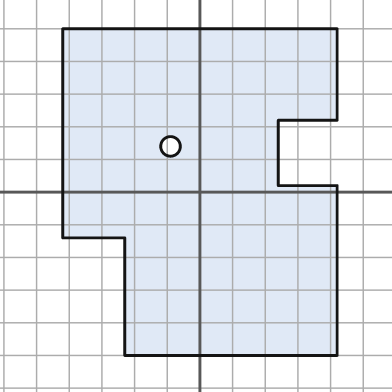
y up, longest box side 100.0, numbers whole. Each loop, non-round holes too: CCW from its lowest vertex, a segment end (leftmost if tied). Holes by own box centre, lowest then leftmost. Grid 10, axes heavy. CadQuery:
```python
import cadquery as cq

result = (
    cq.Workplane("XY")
    .moveTo(-23.0, -50.0)
    .lineTo(42.0, -50.0)
    .lineTo(42.0, 2.0)
    .lineTo(24.0, 2.0)
    .lineTo(24.0, 22.0)
    .lineTo(42.0, 22.0)
    .lineTo(42.0, 50.0)
    .lineTo(-42.0, 50.0)
    .lineTo(-42.0, -14.0)
    .lineTo(-23.0, -14.0)
    .close()
    .moveTo(-9.0, 14.0)
    .circle(3.0)
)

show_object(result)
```